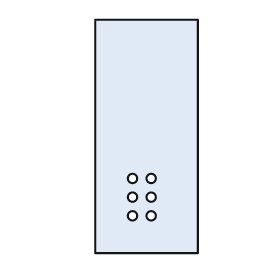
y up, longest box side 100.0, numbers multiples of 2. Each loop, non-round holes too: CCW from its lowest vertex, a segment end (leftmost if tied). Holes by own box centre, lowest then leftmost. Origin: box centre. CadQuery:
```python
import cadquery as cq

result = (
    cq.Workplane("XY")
    .moveTo(-22.0, -50.0)
    .lineTo(22.0, -50.0)
    .lineTo(22.0, 50.0)
    .lineTo(-22.0, 50.0)
    .close()
    .moveTo(-6.0, -34.0)
    .circle(2.0)
    .moveTo(2.0, -34.0)
    .circle(2.0)
    .moveTo(-6.0, -26.0)
    .circle(2.0)
    .moveTo(2.0, -26.0)
    .circle(2.0)
    .moveTo(-6.0, -18.0)
    .circle(2.0)
    .moveTo(2.0, -18.0)
    .circle(2.0)
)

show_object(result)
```